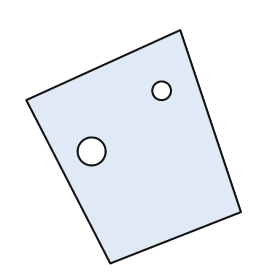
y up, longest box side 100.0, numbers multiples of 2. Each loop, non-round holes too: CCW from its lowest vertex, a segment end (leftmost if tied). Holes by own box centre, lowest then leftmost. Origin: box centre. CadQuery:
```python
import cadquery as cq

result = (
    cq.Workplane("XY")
    .moveTo(-10.0, -50.0)
    .lineTo(46.0, -28.0)
    .lineTo(20.0, 50.0)
    .lineTo(-46.0, 20.0)
    .close()
    .moveTo(-18.0, -2.0)
    .circle(6.0)
    .moveTo(12.0, 24.0)
    .circle(4.0)
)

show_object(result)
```